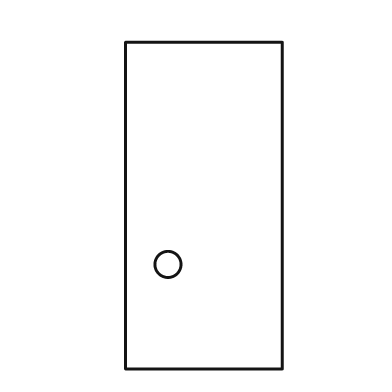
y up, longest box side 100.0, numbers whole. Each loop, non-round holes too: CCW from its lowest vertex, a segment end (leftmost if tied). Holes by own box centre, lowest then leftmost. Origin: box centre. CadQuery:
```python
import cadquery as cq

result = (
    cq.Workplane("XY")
    .moveTo(-24.0, -50.0)
    .lineTo(24.0, -50.0)
    .lineTo(24.0, 50.0)
    .lineTo(-24.0, 50.0)
    .close()
    .moveTo(-11.0, -18.0)
    .circle(4.0)
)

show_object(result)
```